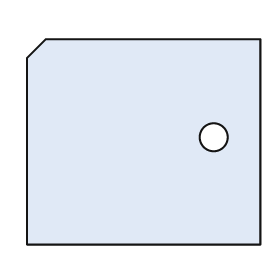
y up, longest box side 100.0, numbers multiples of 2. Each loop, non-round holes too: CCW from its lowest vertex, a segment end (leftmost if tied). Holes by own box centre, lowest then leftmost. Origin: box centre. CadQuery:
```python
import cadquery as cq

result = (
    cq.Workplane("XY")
    .moveTo(-50.0, -44.0)
    .lineTo(50.0, -44.0)
    .lineTo(50.0, 44.0)
    .lineTo(-42.0, 44.0)
    .lineTo(-50.0, 36.0)
    .close()
    .moveTo(30.0, 2.0)
    .circle(6.0)
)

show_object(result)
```